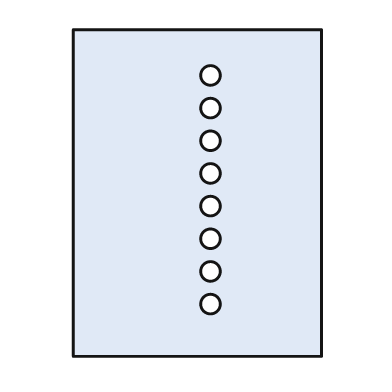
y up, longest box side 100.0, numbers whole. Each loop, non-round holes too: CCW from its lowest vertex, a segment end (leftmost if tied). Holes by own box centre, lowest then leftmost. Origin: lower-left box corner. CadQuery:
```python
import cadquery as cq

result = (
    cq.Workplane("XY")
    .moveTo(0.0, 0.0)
    .lineTo(76.0, 0.0)
    .lineTo(76.0, 100.0)
    .lineTo(0.0, 100.0)
    .close()
    .moveTo(42.0, 16.0)
    .circle(3.0)
    .moveTo(42.0, 26.0)
    .circle(3.0)
    .moveTo(42.0, 36.0)
    .circle(3.0)
    .moveTo(42.0, 46.0)
    .circle(3.0)
    .moveTo(42.0, 56.0)
    .circle(3.0)
    .moveTo(42.0, 66.0)
    .circle(3.0)
    .moveTo(42.0, 76.0)
    .circle(3.0)
    .moveTo(42.0, 86.0)
    .circle(3.0)
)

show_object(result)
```